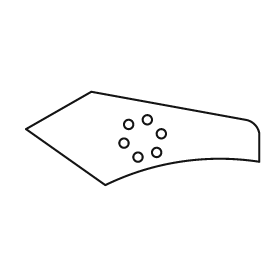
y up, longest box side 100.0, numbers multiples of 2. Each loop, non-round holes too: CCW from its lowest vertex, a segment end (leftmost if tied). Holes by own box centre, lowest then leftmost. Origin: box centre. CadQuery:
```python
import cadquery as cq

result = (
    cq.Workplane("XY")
    .moveTo(-16.0, -20.0)
    .threePointArc((16.0, -10.0), (50.0, -10.0))
    .lineTo(50.0, 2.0)
    .threePointArc((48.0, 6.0), (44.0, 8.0))
    .lineTo(-22.0, 20.0)
    .lineTo(-50.0, 4.0)
    .close()
    .moveTo(-2.0, -8.0)
    .circle(2.0)
    .moveTo(6.0, -6.0)
    .circle(2.0)
    .moveTo(-8.0, -2.0)
    .circle(2.0)
    .moveTo(8.0, 2.0)
    .circle(2.0)
    .moveTo(-6.0, 6.0)
    .circle(2.0)
    .moveTo(2.0, 8.0)
    .circle(2.0)
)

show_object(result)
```